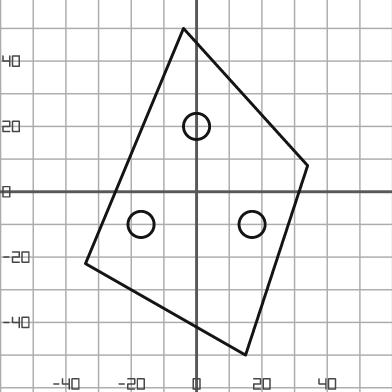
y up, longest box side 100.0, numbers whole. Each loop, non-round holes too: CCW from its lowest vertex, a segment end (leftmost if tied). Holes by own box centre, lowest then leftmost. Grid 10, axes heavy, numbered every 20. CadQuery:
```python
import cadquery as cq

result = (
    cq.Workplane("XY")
    .moveTo(15.0, -50.0)
    .lineTo(34.0, 8.0)
    .lineTo(-4.0, 50.0)
    .lineTo(-34.0, -22.0)
    .close()
    .moveTo(-17.0, -10.0)
    .circle(4.0)
    .moveTo(17.0, -10.0)
    .circle(4.0)
    .moveTo(0.0, 20.0)
    .circle(4.0)
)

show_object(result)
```